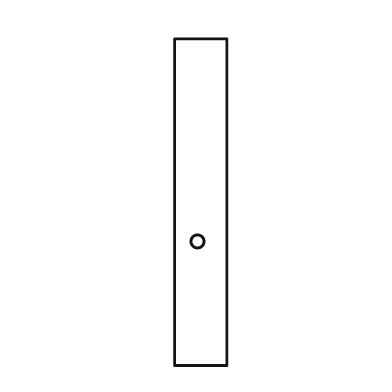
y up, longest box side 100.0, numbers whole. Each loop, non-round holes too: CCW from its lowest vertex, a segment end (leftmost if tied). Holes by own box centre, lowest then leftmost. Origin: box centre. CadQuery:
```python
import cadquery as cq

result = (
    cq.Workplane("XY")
    .moveTo(-8.0, -50.0)
    .lineTo(8.0, -50.0)
    .lineTo(8.0, 50.0)
    .lineTo(-8.0, 50.0)
    .close()
    .moveTo(-1.0, -12.0)
    .circle(2.0)
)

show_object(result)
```